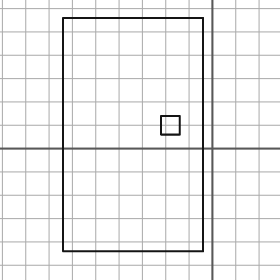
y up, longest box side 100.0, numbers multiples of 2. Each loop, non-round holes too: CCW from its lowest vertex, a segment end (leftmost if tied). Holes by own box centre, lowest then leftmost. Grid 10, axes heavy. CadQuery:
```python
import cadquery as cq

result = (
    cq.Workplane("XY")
    .moveTo(-64.0, -44.0)
    .lineTo(-4.0, -44.0)
    .lineTo(-4.0, 56.0)
    .lineTo(-64.0, 56.0)
    .close()
    .moveTo(-22.0, 6.0)
    .lineTo(-14.0, 6.0)
    .lineTo(-14.0, 14.0)
    .lineTo(-22.0, 14.0)
    .close()
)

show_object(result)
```